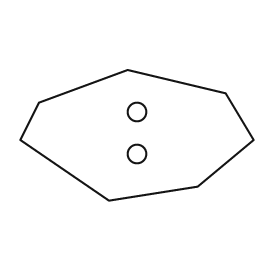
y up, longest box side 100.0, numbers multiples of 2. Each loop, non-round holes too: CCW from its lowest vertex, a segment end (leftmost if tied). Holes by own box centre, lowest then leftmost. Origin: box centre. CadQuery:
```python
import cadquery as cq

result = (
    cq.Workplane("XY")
    .moveTo(-12.0, -28.0)
    .lineTo(26.0, -22.0)
    .lineTo(50.0, -2.0)
    .lineTo(38.0, 18.0)
    .lineTo(-4.0, 28.0)
    .lineTo(-42.0, 14.0)
    .lineTo(-50.0, -2.0)
    .close()
    .moveTo(0.0, -8.0)
    .circle(4.0)
    .moveTo(0.0, 10.0)
    .circle(4.0)
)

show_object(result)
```